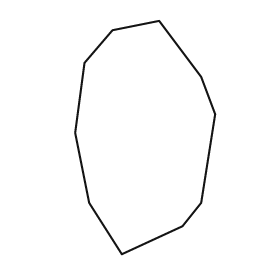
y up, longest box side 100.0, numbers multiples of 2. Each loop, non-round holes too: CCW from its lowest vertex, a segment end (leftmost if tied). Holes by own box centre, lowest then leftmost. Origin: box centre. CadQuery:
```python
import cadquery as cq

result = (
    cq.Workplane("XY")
    .moveTo(-10.0, -50.0)
    .lineTo(16.0, -38.0)
    .lineTo(24.0, -28.0)
    .lineTo(30.0, 10.0)
    .lineTo(24.0, 26.0)
    .lineTo(6.0, 50.0)
    .lineTo(-14.0, 46.0)
    .lineTo(-26.0, 32.0)
    .lineTo(-30.0, 2.0)
    .lineTo(-24.0, -28.0)
    .close()
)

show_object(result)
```